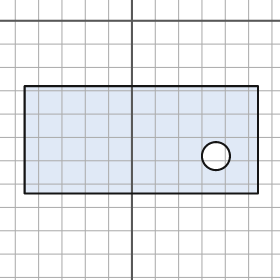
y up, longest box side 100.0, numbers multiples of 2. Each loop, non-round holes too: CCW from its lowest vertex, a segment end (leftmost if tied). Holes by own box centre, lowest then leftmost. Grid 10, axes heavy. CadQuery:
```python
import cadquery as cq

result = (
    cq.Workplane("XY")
    .moveTo(-46.0, -74.0)
    .lineTo(54.0, -74.0)
    .lineTo(54.0, -28.0)
    .lineTo(-46.0, -28.0)
    .close()
    .moveTo(36.0, -58.0)
    .circle(6.0)
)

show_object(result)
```